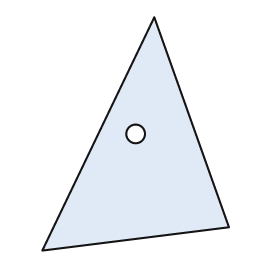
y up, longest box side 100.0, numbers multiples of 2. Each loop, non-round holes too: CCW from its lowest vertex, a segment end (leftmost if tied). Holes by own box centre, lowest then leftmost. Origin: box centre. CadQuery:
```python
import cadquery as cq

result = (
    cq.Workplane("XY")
    .moveTo(-40.0, -50.0)
    .lineTo(40.0, -40.0)
    .lineTo(8.0, 50.0)
    .close()
    .moveTo(0.0, 0.0)
    .circle(4.0)
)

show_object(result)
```